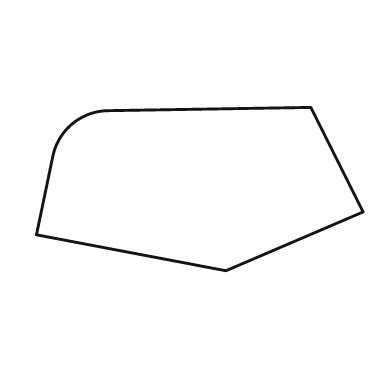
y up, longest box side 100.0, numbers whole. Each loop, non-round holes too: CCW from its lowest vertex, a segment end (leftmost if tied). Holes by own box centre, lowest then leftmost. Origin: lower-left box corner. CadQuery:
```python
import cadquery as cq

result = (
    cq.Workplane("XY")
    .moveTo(58.0, 0.0)
    .lineTo(100.0, 18.0)
    .lineTo(84.0, 50.0)
    .lineTo(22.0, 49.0)
    .threePointArc((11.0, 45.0), (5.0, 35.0))
    .lineTo(0.0, 11.0)
    .close()
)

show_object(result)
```